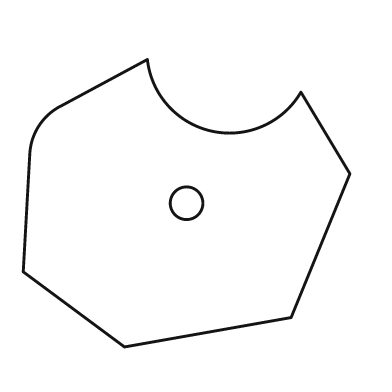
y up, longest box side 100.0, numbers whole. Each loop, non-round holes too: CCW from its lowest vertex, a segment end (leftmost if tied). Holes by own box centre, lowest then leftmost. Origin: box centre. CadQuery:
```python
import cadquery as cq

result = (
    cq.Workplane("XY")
    .moveTo(-19.0, -44.0)
    .lineTo(32.0, -35.0)
    .lineTo(50.0, 9.0)
    .lineTo(35.0, 34.0)
    .threePointArc((8.0, 22.0), (-12.0, 44.0))
    .lineTo(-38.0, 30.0)
    .threePointArc((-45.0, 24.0), (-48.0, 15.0))
    .lineTo(-50.0, -21.0)
    .close()
    .moveTo(0.0, 0.0)
    .circle(5.0)
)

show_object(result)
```